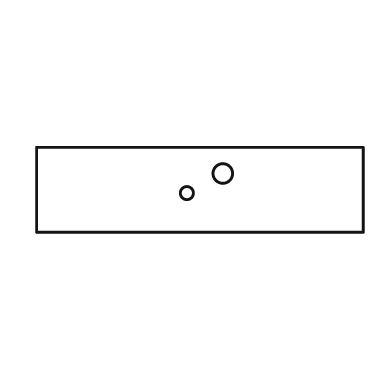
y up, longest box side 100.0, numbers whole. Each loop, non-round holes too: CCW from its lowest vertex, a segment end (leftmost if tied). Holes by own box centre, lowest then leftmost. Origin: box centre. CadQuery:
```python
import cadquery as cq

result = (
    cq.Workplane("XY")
    .moveTo(-50.0, -13.0)
    .lineTo(50.0, -13.0)
    .lineTo(50.0, 13.0)
    .lineTo(-50.0, 13.0)
    .close()
    .moveTo(-4.0, -1.0)
    .circle(2.0)
    .moveTo(7.0, 5.0)
    .circle(3.0)
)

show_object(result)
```